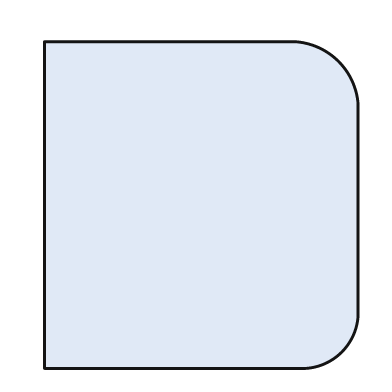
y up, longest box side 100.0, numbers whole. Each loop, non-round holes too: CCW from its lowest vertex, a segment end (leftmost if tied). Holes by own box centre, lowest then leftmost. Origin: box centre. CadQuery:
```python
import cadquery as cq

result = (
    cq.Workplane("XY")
    .moveTo(-48.0, -50.0)
    .lineTo(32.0, -50.0)
    .threePointArc((43.0, -45.0), (48.0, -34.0))
    .lineTo(48.0, 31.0)
    .threePointArc((42.0, 44.0), (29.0, 50.0))
    .lineTo(-48.0, 50.0)
    .close()
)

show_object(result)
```